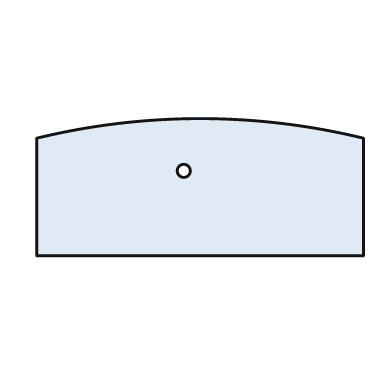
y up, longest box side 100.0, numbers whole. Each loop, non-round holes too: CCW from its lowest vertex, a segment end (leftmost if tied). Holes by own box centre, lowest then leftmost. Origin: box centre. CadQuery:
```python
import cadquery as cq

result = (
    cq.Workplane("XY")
    .moveTo(-50.0, -21.0)
    .lineTo(50.0, -21.0)
    .lineTo(50.0, 15.0)
    .threePointArc((0.0, 21.0), (-50.0, 15.0))
    .close()
    .moveTo(-5.0, 5.0)
    .circle(2.0)
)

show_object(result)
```